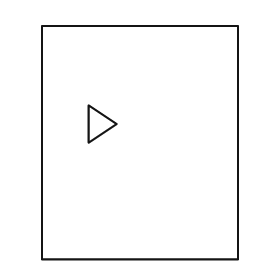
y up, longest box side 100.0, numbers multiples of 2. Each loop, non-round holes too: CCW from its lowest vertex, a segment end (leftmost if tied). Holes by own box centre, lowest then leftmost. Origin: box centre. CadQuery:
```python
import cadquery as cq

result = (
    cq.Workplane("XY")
    .moveTo(-42.0, -50.0)
    .lineTo(42.0, -50.0)
    .lineTo(42.0, 50.0)
    .lineTo(-42.0, 50.0)
    .close()
    .moveTo(-22.0, 0.0)
    .lineTo(-10.0, 8.0)
    .lineTo(-22.0, 16.0)
    .close()
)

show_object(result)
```